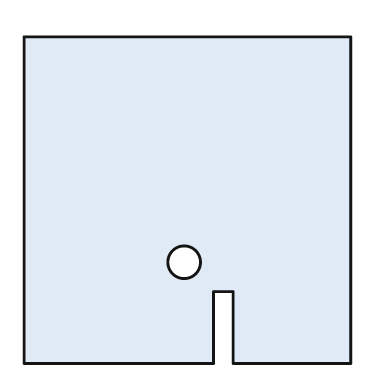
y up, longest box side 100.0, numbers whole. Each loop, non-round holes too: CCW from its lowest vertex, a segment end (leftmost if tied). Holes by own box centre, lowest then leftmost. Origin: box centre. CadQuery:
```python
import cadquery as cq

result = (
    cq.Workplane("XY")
    .moveTo(-50.0, -50.0)
    .lineTo(8.0, -50.0)
    .lineTo(8.0, -28.0)
    .lineTo(14.0, -28.0)
    .lineTo(14.0, -50.0)
    .lineTo(50.0, -50.0)
    .lineTo(50.0, 50.0)
    .lineTo(-50.0, 50.0)
    .close()
    .moveTo(-1.0, -19.0)
    .circle(5.0)
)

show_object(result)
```